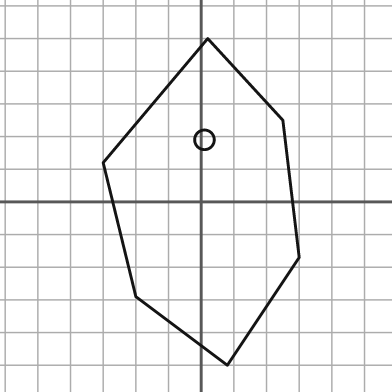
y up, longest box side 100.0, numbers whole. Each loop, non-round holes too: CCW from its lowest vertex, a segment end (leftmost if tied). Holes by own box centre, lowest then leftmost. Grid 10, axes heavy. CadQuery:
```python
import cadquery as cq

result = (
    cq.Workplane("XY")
    .moveTo(8.0, -50.0)
    .lineTo(30.0, -17.0)
    .lineTo(25.0, 25.0)
    .lineTo(2.0, 50.0)
    .lineTo(-30.0, 12.0)
    .lineTo(-20.0, -29.0)
    .close()
    .moveTo(1.0, 19.0)
    .circle(3.0)
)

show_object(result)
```